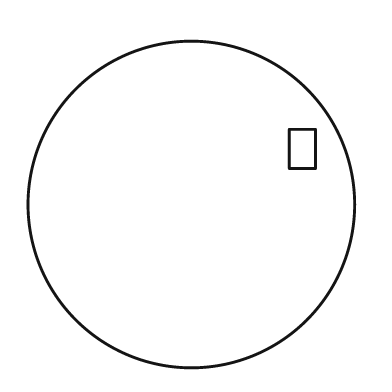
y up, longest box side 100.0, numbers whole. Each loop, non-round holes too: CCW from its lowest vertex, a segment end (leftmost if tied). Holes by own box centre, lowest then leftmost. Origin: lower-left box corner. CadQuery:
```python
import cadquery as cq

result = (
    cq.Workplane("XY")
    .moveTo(50.0, 50.0)
    .circle(50.0)
    .moveTo(80.0, 61.0)
    .lineTo(88.0, 61.0)
    .lineTo(88.0, 73.0)
    .lineTo(80.0, 73.0)
    .close()
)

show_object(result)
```